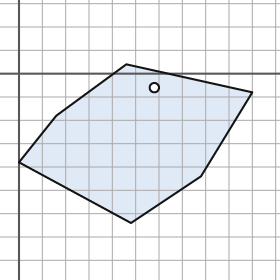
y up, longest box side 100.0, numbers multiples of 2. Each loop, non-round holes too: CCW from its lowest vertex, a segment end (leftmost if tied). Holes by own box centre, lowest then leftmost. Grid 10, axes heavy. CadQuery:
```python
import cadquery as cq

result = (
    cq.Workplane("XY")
    .moveTo(48.0, -64.0)
    .lineTo(78.0, -44.0)
    .lineTo(100.0, -8.0)
    .lineTo(46.0, 4.0)
    .lineTo(16.0, -18.0)
    .lineTo(0.0, -38.0)
    .close()
    .moveTo(58.0, -6.0)
    .circle(2.0)
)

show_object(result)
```